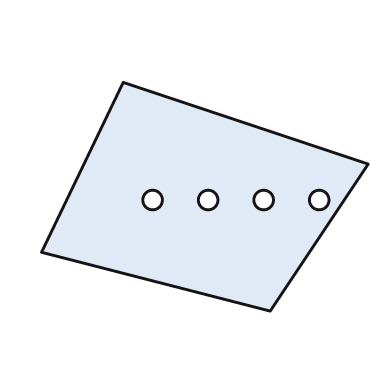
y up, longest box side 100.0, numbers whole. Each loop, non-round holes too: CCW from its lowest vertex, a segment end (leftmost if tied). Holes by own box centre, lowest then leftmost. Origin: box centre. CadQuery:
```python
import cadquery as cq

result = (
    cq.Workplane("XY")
    .moveTo(20.0, -35.0)
    .lineTo(50.0, 10.0)
    .lineTo(-25.0, 35.0)
    .lineTo(-50.0, -17.0)
    .close()
    .moveTo(-16.0, -1.0)
    .circle(3.0)
    .moveTo(1.0, -1.0)
    .circle(3.0)
    .moveTo(18.0, -1.0)
    .circle(3.0)
    .moveTo(35.0, -1.0)
    .circle(3.0)
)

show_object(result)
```